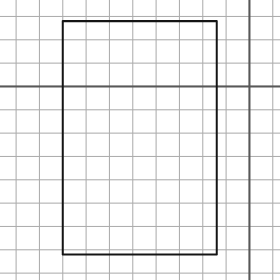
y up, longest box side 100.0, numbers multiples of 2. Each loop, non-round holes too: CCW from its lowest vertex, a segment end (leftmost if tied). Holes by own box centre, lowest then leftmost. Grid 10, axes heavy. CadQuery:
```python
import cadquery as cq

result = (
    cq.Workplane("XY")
    .moveTo(-80.0, -72.0)
    .lineTo(-14.0, -72.0)
    .lineTo(-14.0, 28.0)
    .lineTo(-80.0, 28.0)
    .close()
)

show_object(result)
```